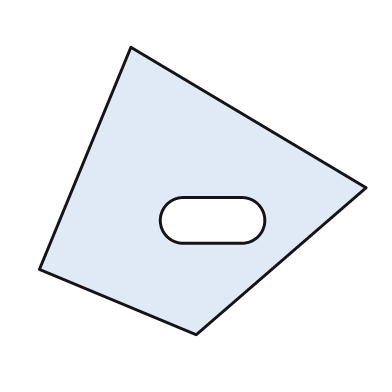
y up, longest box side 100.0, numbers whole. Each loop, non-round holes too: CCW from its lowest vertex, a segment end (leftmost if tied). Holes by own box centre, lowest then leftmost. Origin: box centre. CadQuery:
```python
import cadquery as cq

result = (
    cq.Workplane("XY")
    .moveTo(-2.0, -44.0)
    .lineTo(50.0, 1.0)
    .lineTo(-22.0, 44.0)
    .lineTo(-50.0, -24.0)
    .close()
    .moveTo(-6.0, -16.0)
    .lineTo(12.0, -16.0)
    .threePointArc((19.0, -9.0), (12.0, -2.0))
    .lineTo(-6.0, -2.0)
    .threePointArc((-13.0, -9.0), (-6.0, -16.0))
    .close()
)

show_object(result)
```